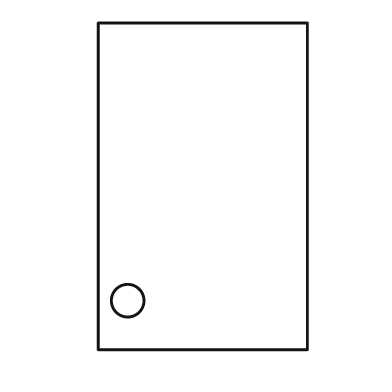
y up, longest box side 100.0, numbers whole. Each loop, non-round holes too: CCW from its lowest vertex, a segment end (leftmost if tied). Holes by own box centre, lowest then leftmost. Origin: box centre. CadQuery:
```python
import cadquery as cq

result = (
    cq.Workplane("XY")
    .moveTo(-32.0, -50.0)
    .lineTo(32.0, -50.0)
    .lineTo(32.0, 50.0)
    .lineTo(-32.0, 50.0)
    .close()
    .moveTo(-23.0, -35.0)
    .circle(5.0)
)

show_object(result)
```